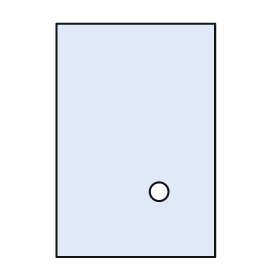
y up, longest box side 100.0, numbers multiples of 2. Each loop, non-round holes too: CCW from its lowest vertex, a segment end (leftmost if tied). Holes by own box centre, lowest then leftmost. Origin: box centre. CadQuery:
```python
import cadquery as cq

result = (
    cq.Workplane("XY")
    .moveTo(-34.0, -50.0)
    .lineTo(34.0, -50.0)
    .lineTo(34.0, 50.0)
    .lineTo(-34.0, 50.0)
    .close()
    .moveTo(10.0, -22.0)
    .circle(4.0)
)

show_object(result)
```